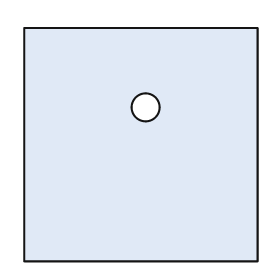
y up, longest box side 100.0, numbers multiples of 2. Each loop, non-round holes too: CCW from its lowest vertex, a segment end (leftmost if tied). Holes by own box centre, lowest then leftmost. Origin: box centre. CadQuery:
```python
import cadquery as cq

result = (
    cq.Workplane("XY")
    .moveTo(-50.0, -50.0)
    .lineTo(50.0, -50.0)
    .lineTo(50.0, 50.0)
    .lineTo(-50.0, 50.0)
    .close()
    .moveTo(2.0, 16.0)
    .circle(6.0)
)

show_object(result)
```